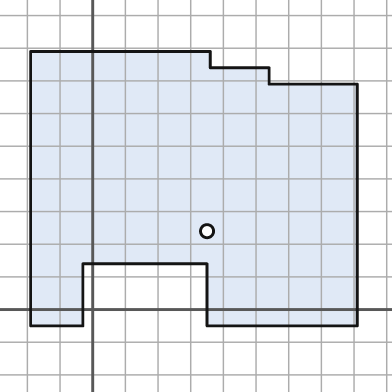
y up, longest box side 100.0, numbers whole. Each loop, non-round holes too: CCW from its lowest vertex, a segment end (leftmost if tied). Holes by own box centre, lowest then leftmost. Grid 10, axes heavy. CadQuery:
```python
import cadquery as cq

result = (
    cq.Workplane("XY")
    .moveTo(-19.0, -5.0)
    .lineTo(-3.0, -5.0)
    .lineTo(-3.0, 14.0)
    .lineTo(35.0, 14.0)
    .lineTo(35.0, -5.0)
    .lineTo(81.0, -5.0)
    .lineTo(81.0, 69.0)
    .lineTo(54.0, 69.0)
    .lineTo(54.0, 74.0)
    .lineTo(36.0, 74.0)
    .lineTo(36.0, 79.0)
    .lineTo(-19.0, 79.0)
    .close()
    .moveTo(35.0, 24.0)
    .circle(2.0)
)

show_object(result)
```